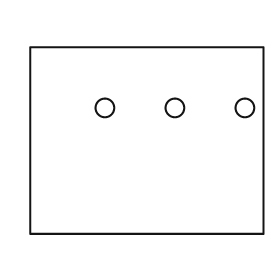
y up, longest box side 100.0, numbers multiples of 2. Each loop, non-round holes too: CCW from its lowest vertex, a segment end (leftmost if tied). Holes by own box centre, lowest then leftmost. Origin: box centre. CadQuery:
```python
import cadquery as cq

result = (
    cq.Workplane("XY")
    .moveTo(-50.0, -40.0)
    .lineTo(50.0, -40.0)
    .lineTo(50.0, 40.0)
    .lineTo(-50.0, 40.0)
    .close()
    .moveTo(-18.0, 14.0)
    .circle(4.0)
    .moveTo(12.0, 14.0)
    .circle(4.0)
    .moveTo(42.0, 14.0)
    .circle(4.0)
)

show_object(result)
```